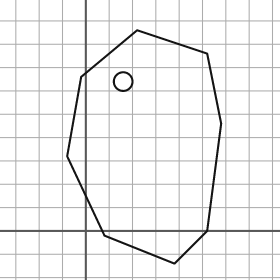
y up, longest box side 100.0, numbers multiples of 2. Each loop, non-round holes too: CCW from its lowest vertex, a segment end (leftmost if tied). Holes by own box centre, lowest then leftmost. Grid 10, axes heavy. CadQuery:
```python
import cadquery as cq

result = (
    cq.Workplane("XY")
    .moveTo(38.0, -14.0)
    .lineTo(52.0, 0.0)
    .lineTo(58.0, 46.0)
    .lineTo(52.0, 76.0)
    .lineTo(22.0, 86.0)
    .lineTo(-2.0, 66.0)
    .lineTo(-8.0, 32.0)
    .lineTo(8.0, -2.0)
    .close()
    .moveTo(16.0, 64.0)
    .circle(4.0)
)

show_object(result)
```